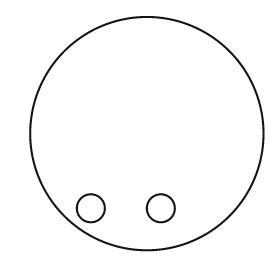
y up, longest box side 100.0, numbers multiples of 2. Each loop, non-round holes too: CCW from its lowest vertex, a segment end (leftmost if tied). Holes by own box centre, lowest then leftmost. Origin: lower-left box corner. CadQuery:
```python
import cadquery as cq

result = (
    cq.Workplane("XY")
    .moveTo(50.0, 50.0)
    .circle(50.0)
    .moveTo(26.0, 18.0)
    .circle(6.0)
    .moveTo(56.0, 18.0)
    .circle(6.0)
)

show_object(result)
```